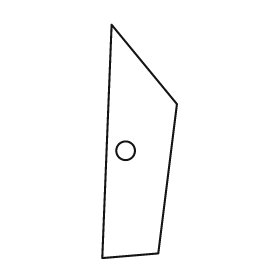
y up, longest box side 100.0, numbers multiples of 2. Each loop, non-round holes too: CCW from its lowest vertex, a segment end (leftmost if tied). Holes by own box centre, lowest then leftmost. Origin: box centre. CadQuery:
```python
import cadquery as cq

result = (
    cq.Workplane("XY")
    .moveTo(-16.0, -50.0)
    .lineTo(8.0, -48.0)
    .lineTo(16.0, 16.0)
    .lineTo(-12.0, 50.0)
    .close()
    .moveTo(-6.0, -4.0)
    .circle(4.0)
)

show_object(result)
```